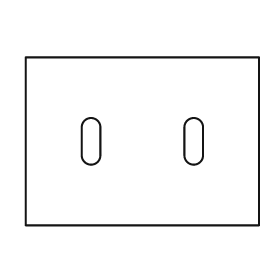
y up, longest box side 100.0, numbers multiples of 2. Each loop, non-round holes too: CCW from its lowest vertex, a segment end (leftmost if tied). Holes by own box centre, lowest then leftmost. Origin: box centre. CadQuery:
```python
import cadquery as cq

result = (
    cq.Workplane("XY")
    .moveTo(-50.0, -36.0)
    .lineTo(50.0, -36.0)
    .lineTo(50.0, 36.0)
    .lineTo(-50.0, 36.0)
    .close()
    .moveTo(-26.0, -6.0)
    .threePointArc((-22.0, -10.0), (-18.0, -6.0))
    .lineTo(-18.0, 6.0)
    .threePointArc((-22.0, 10.0), (-26.0, 6.0))
    .close()
    .moveTo(18.0, -6.0)
    .threePointArc((22.0, -10.0), (26.0, -6.0))
    .lineTo(26.0, 6.0)
    .threePointArc((22.0, 10.0), (18.0, 6.0))
    .close()
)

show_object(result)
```